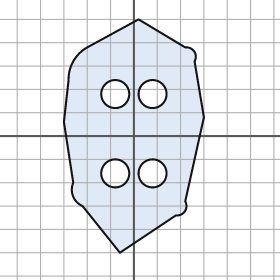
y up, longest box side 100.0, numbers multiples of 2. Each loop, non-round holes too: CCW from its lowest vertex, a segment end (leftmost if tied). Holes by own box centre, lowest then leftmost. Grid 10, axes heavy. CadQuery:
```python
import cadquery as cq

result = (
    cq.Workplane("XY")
    .moveTo(-6.0, -50.0)
    .lineTo(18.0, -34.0)
    .threePointArc((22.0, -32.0), (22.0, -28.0))
    .lineTo(30.0, 8.0)
    .lineTo(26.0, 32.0)
    .threePointArc((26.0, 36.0), (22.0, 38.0))
    .lineTo(2.0, 50.0)
    .lineTo(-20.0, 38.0)
    .threePointArc((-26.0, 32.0), (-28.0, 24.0))
    .lineTo(-30.0, 6.0)
    .lineTo(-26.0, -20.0)
    .threePointArc((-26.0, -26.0), (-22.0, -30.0))
    .close()
    .moveTo(-8.0, -16.0)
    .circle(6.0)
    .moveTo(8.0, -16.0)
    .circle(6.0)
    .moveTo(-8.0, 18.0)
    .circle(6.0)
    .moveTo(8.0, 18.0)
    .circle(6.0)
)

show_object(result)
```